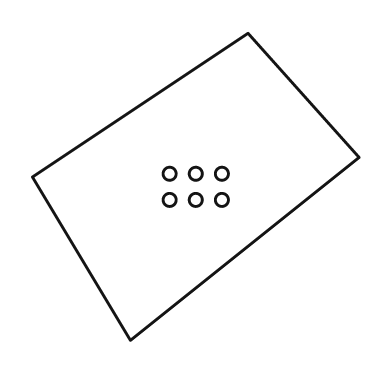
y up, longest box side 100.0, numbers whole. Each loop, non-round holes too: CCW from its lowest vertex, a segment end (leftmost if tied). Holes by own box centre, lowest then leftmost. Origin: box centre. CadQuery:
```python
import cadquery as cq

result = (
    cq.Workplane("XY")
    .moveTo(-20.0, -47.0)
    .lineTo(50.0, 9.0)
    .lineTo(16.0, 47.0)
    .lineTo(-50.0, 3.0)
    .close()
    .moveTo(-8.0, -4.0)
    .circle(2.0)
    .moveTo(0.0, -4.0)
    .circle(2.0)
    .moveTo(8.0, -4.0)
    .circle(2.0)
    .moveTo(-8.0, 4.0)
    .circle(2.0)
    .moveTo(0.0, 4.0)
    .circle(2.0)
    .moveTo(8.0, 4.0)
    .circle(2.0)
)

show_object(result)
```